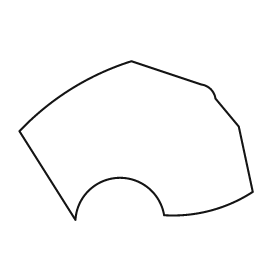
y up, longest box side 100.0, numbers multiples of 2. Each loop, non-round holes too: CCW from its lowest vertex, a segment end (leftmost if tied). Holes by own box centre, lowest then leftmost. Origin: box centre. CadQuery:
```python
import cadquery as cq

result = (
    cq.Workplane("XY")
    .moveTo(-26.0, -34.0)
    .threePointArc((-8.0, -16.0), (12.0, -32.0))
    .threePointArc((32.0, -30.0), (50.0, -22.0))
    .lineTo(44.0, 6.0)
    .lineTo(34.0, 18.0)
    .threePointArc((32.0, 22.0), (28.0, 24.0))
    .lineTo(-2.0, 34.0)
    .threePointArc((-28.0, 22.0), (-50.0, 4.0))
    .close()
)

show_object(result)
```